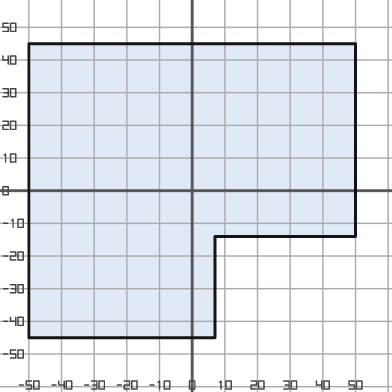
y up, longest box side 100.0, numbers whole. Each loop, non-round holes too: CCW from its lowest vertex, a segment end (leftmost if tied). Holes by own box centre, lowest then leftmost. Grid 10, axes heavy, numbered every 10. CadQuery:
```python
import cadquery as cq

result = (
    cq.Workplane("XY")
    .moveTo(-50.0, -45.0)
    .lineTo(7.0, -45.0)
    .lineTo(7.0, -14.0)
    .lineTo(50.0, -14.0)
    .lineTo(50.0, 45.0)
    .lineTo(-50.0, 45.0)
    .close()
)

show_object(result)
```